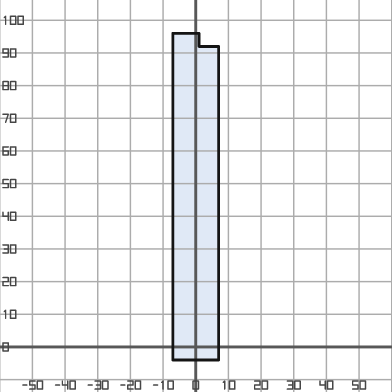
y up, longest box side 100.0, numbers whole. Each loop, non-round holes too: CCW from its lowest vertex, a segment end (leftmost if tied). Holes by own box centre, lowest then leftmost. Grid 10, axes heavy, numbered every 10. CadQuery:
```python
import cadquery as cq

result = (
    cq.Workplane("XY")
    .moveTo(-7.0, -4.0)
    .lineTo(7.0, -4.0)
    .lineTo(7.0, 92.0)
    .lineTo(1.0, 92.0)
    .lineTo(1.0, 96.0)
    .lineTo(-7.0, 96.0)
    .close()
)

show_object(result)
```